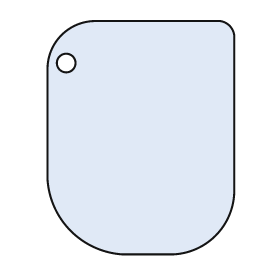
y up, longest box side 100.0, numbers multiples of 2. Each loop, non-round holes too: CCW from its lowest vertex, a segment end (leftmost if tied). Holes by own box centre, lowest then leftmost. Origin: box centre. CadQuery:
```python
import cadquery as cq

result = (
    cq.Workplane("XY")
    .moveTo(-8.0, -50.0)
    .lineTo(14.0, -50.0)
    .threePointArc((32.0, -42.0), (40.0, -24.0))
    .lineTo(40.0, 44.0)
    .threePointArc((38.0, 48.0), (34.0, 50.0))
    .lineTo(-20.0, 50.0)
    .threePointArc((-34.0, 44.0), (-40.0, 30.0))
    .lineTo(-40.0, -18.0)
    .threePointArc((-30.0, -40.0), (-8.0, -50.0))
    .close()
    .moveTo(-32.0, 32.0)
    .circle(4.0)
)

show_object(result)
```